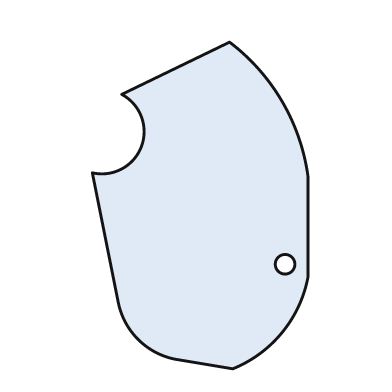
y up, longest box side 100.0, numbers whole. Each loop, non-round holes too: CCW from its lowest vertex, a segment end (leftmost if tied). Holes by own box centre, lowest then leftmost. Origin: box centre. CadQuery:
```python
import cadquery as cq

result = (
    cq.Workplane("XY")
    .moveTo(10.0, -50.0)
    .threePointArc((25.0, -39.0), (33.0, -22.0))
    .lineTo(33.0, 9.0)
    .threePointArc((25.0, 32.0), (9.0, 50.0))
    .lineTo(-24.0, 34.0)
    .threePointArc((-18.0, 18.0), (-33.0, 10.0))
    .lineTo(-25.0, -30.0)
    .threePointArc((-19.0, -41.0), (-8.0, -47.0))
    .close()
    .moveTo(26.0, -18.0)
    .circle(3.0)
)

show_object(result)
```